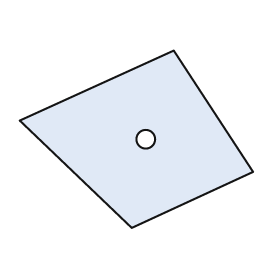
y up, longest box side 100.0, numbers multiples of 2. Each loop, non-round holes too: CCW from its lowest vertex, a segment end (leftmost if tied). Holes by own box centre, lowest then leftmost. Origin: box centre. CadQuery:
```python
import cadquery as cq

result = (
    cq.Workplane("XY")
    .moveTo(-2.0, -38.0)
    .lineTo(50.0, -14.0)
    .lineTo(16.0, 38.0)
    .lineTo(-50.0, 8.0)
    .close()
    .moveTo(4.0, 0.0)
    .circle(4.0)
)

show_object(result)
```